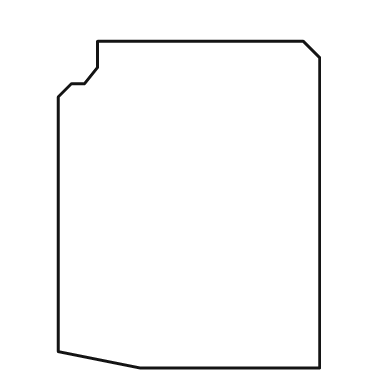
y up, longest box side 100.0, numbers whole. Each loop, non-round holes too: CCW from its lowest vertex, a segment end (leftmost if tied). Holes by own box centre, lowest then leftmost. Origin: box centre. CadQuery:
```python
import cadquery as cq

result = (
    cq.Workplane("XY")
    .moveTo(-15.0, -50.0)
    .lineTo(40.0, -50.0)
    .lineTo(40.0, 45.0)
    .lineTo(35.0, 50.0)
    .lineTo(-28.0, 50.0)
    .lineTo(-28.0, 42.0)
    .lineTo(-32.0, 37.0)
    .lineTo(-36.0, 37.0)
    .lineTo(-40.0, 33.0)
    .lineTo(-40.0, -45.0)
    .close()
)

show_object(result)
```